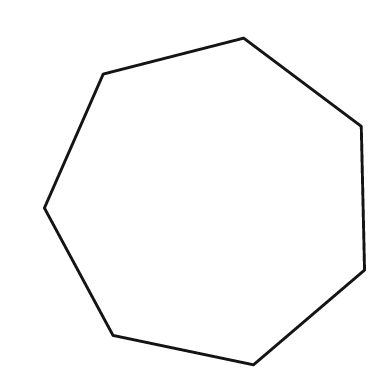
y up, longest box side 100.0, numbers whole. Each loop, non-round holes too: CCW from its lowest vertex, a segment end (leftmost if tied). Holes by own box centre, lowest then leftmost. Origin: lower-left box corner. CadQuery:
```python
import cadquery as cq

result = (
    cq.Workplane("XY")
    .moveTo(64.0, 0.0)
    .lineTo(98.0, 29.0)
    .lineTo(97.0, 73.0)
    .lineTo(61.0, 100.0)
    .lineTo(18.0, 89.0)
    .lineTo(0.0, 48.0)
    .lineTo(21.0, 9.0)
    .close()
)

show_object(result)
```